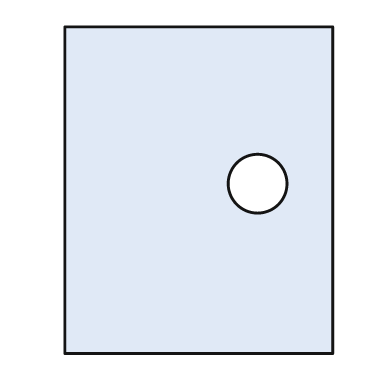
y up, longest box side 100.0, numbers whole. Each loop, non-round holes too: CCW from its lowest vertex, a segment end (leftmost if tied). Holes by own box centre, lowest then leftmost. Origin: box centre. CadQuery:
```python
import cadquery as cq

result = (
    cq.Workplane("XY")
    .moveTo(-41.0, -50.0)
    .lineTo(41.0, -50.0)
    .lineTo(41.0, 50.0)
    .lineTo(-41.0, 50.0)
    .close()
    .moveTo(18.0, 2.0)
    .circle(9.0)
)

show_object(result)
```